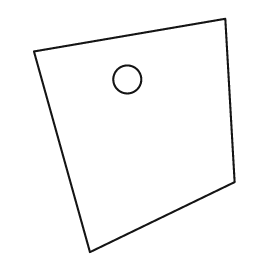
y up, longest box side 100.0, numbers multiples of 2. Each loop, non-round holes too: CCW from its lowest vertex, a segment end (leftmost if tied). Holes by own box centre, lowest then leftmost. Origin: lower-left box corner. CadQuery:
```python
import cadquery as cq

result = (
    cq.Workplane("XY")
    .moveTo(24.0, 0.0)
    .lineTo(86.0, 30.0)
    .lineTo(82.0, 100.0)
    .lineTo(0.0, 86.0)
    .close()
    .moveTo(40.0, 74.0)
    .circle(6.0)
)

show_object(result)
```